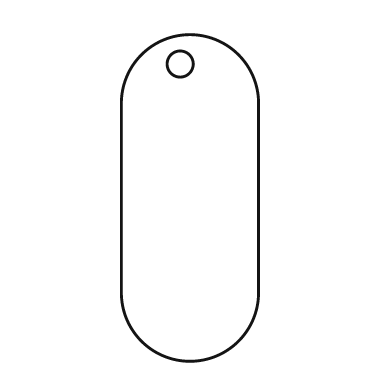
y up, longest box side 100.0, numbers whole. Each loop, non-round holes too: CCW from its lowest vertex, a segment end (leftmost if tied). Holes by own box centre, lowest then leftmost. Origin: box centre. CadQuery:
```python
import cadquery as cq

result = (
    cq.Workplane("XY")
    .moveTo(-21.0, -29.0)
    .threePointArc((0.0, -50.0), (21.0, -29.0))
    .lineTo(21.0, 29.0)
    .threePointArc((0.0, 50.0), (-21.0, 29.0))
    .close()
    .moveTo(-3.0, 41.0)
    .circle(4.0)
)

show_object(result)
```